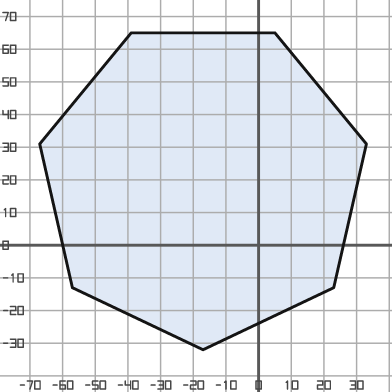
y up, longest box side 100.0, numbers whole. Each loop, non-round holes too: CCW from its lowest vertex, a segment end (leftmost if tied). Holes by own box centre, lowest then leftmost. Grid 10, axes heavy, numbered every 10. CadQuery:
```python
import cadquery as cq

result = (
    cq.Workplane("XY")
    .moveTo(-17.0, -32.0)
    .lineTo(23.0, -13.0)
    .lineTo(33.0, 31.0)
    .lineTo(5.0, 65.0)
    .lineTo(-39.0, 65.0)
    .lineTo(-67.0, 31.0)
    .lineTo(-57.0, -13.0)
    .close()
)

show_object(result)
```